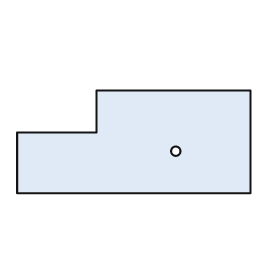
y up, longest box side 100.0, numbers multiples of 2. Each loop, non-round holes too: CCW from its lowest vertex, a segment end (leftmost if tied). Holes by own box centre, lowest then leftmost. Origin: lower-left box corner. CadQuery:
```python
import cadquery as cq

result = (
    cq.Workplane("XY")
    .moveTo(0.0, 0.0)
    .lineTo(100.0, 0.0)
    .lineTo(100.0, 44.0)
    .lineTo(34.0, 44.0)
    .lineTo(34.0, 26.0)
    .lineTo(0.0, 26.0)
    .close()
    .moveTo(68.0, 18.0)
    .circle(2.0)
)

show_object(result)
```